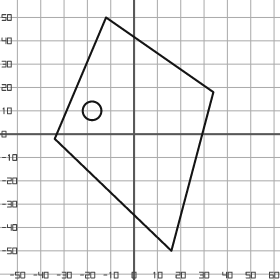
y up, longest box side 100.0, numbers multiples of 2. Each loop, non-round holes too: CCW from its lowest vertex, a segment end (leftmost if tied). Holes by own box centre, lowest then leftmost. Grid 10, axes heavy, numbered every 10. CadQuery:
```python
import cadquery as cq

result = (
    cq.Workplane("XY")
    .moveTo(16.0, -50.0)
    .lineTo(34.0, 18.0)
    .lineTo(-12.0, 50.0)
    .lineTo(-34.0, -2.0)
    .close()
    .moveTo(-18.0, 10.0)
    .circle(4.0)
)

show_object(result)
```